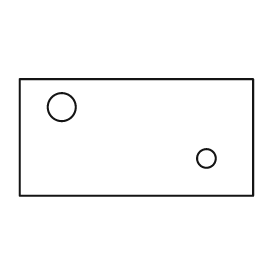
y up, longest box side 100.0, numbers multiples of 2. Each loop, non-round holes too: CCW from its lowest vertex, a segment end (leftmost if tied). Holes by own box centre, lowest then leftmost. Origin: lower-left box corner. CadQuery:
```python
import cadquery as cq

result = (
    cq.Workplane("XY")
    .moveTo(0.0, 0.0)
    .lineTo(100.0, 0.0)
    .lineTo(100.0, 50.0)
    .lineTo(0.0, 50.0)
    .close()
    .moveTo(80.0, 16.0)
    .circle(4.0)
    .moveTo(18.0, 38.0)
    .circle(6.0)
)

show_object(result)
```